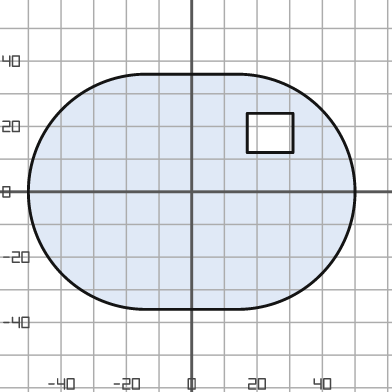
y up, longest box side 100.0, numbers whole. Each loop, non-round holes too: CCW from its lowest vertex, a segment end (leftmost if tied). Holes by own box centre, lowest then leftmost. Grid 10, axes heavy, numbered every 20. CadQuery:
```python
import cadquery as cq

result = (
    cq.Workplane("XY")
    .moveTo(-14.0, -36.0)
    .lineTo(14.0, -36.0)
    .threePointArc((50.0, 0.0), (14.0, 36.0))
    .lineTo(-14.0, 36.0)
    .threePointArc((-50.0, 0.0), (-14.0, -36.0))
    .close()
    .moveTo(17.0, 12.0)
    .lineTo(31.0, 12.0)
    .lineTo(31.0, 24.0)
    .lineTo(17.0, 24.0)
    .close()
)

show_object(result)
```